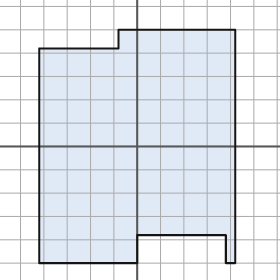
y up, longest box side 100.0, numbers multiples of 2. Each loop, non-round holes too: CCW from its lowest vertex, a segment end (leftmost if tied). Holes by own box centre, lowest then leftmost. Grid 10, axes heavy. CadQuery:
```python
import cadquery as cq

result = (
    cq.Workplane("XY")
    .moveTo(-42.0, -50.0)
    .lineTo(0.0, -50.0)
    .lineTo(0.0, -38.0)
    .lineTo(38.0, -38.0)
    .lineTo(38.0, -50.0)
    .lineTo(42.0, -50.0)
    .lineTo(42.0, 50.0)
    .lineTo(-8.0, 50.0)
    .lineTo(-8.0, 42.0)
    .lineTo(-42.0, 42.0)
    .close()
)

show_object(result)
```